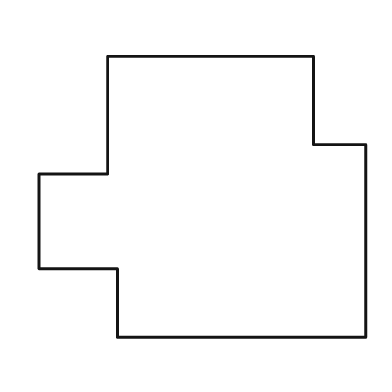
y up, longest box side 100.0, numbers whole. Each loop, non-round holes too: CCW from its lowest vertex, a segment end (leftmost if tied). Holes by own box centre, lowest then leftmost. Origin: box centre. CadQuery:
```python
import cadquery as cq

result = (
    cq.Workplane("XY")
    .moveTo(-26.0, -43.0)
    .lineTo(50.0, -43.0)
    .lineTo(50.0, 16.0)
    .lineTo(34.0, 16.0)
    .lineTo(34.0, 43.0)
    .lineTo(-29.0, 43.0)
    .lineTo(-29.0, 7.0)
    .lineTo(-50.0, 7.0)
    .lineTo(-50.0, -22.0)
    .lineTo(-26.0, -22.0)
    .close()
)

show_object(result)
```